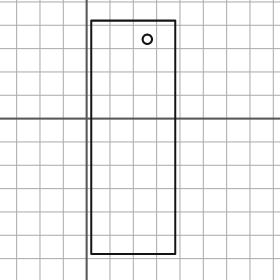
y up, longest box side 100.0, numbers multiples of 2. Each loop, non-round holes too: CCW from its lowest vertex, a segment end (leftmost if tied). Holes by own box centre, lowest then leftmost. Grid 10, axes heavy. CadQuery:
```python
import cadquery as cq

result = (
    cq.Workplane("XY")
    .moveTo(2.0, -58.0)
    .lineTo(38.0, -58.0)
    .lineTo(38.0, 42.0)
    .lineTo(2.0, 42.0)
    .close()
    .moveTo(26.0, 34.0)
    .circle(2.0)
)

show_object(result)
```